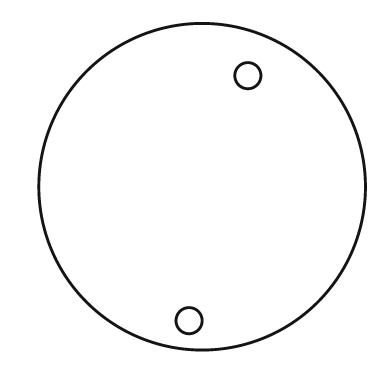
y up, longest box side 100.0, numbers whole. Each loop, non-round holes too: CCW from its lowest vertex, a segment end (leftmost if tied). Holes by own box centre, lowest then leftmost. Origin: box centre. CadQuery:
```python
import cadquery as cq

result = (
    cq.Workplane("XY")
    .moveTo(0.0, 0.0)
    .circle(50.0)
    .moveTo(-4.0, -41.0)
    .circle(4.0)
    .moveTo(14.0, 34.0)
    .circle(4.0)
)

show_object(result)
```